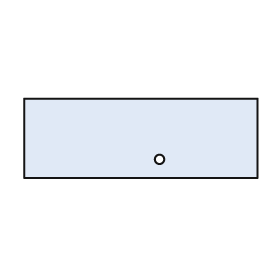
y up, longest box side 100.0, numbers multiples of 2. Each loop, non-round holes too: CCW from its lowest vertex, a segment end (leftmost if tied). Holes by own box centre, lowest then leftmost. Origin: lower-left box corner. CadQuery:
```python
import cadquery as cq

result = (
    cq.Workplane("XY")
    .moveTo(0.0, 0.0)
    .lineTo(100.0, 0.0)
    .lineTo(100.0, 34.0)
    .lineTo(0.0, 34.0)
    .close()
    .moveTo(58.0, 8.0)
    .circle(2.0)
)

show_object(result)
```